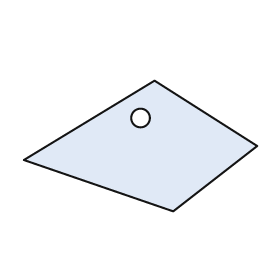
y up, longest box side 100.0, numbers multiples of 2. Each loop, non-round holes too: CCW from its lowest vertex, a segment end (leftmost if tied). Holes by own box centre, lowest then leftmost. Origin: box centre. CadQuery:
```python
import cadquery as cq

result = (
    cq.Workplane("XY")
    .moveTo(14.0, -28.0)
    .lineTo(50.0, 0.0)
    .lineTo(6.0, 28.0)
    .lineTo(-50.0, -6.0)
    .close()
    .moveTo(0.0, 12.0)
    .circle(4.0)
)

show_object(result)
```